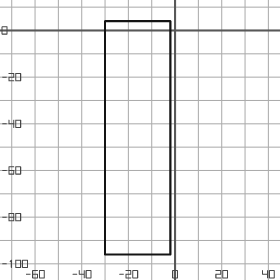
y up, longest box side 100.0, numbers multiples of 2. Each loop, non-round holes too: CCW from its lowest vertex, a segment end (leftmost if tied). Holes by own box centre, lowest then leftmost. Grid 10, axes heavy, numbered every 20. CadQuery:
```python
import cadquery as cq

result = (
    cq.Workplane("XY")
    .moveTo(-30.0, -96.0)
    .lineTo(-2.0, -96.0)
    .lineTo(-2.0, 4.0)
    .lineTo(-30.0, 4.0)
    .close()
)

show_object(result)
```